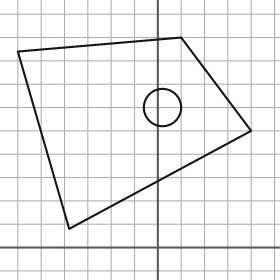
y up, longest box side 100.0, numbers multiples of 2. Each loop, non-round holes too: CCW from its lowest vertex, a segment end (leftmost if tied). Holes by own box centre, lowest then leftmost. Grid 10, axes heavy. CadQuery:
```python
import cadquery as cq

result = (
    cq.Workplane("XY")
    .moveTo(-38.0, 8.0)
    .lineTo(40.0, 50.0)
    .lineTo(10.0, 90.0)
    .lineTo(-60.0, 84.0)
    .close()
    .moveTo(2.0, 60.0)
    .circle(8.0)
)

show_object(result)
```